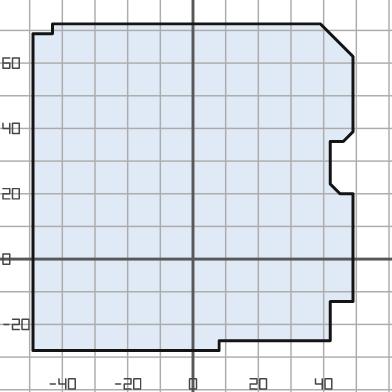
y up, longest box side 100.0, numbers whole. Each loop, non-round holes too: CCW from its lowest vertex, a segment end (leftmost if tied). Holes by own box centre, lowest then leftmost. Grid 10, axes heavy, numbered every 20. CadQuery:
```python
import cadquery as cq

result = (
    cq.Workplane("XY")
    .moveTo(-49.0, -28.0)
    .lineTo(8.0, -28.0)
    .lineTo(8.0, -25.0)
    .lineTo(42.0, -25.0)
    .lineTo(42.0, -13.0)
    .lineTo(49.0, -13.0)
    .lineTo(49.0, 20.0)
    .lineTo(45.0, 20.0)
    .lineTo(42.0, 23.0)
    .lineTo(42.0, 36.0)
    .lineTo(46.0, 36.0)
    .lineTo(49.0, 39.0)
    .lineTo(49.0, 62.0)
    .lineTo(39.0, 72.0)
    .lineTo(-43.0, 72.0)
    .lineTo(-43.0, 69.0)
    .lineTo(-49.0, 69.0)
    .close()
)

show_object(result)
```